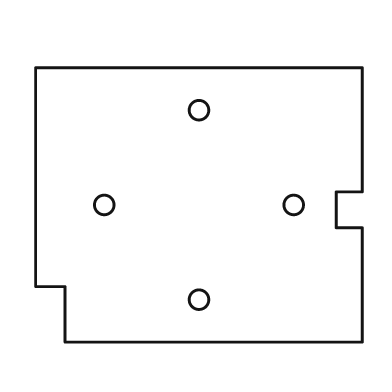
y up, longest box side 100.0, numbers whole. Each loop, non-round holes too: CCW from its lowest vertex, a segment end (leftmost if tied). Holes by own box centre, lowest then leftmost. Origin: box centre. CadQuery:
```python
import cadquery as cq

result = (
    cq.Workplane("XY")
    .moveTo(-41.0, -42.0)
    .lineTo(50.0, -42.0)
    .lineTo(50.0, -7.0)
    .lineTo(42.0, -7.0)
    .lineTo(42.0, 4.0)
    .lineTo(50.0, 4.0)
    .lineTo(50.0, 42.0)
    .lineTo(-50.0, 42.0)
    .lineTo(-50.0, -25.0)
    .lineTo(-41.0, -25.0)
    .close()
    .moveTo(0.0, -29.0)
    .circle(3.0)
    .moveTo(-29.0, 0.0)
    .circle(3.0)
    .moveTo(29.0, 0.0)
    .circle(3.0)
    .moveTo(0.0, 29.0)
    .circle(3.0)
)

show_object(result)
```